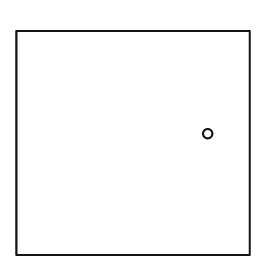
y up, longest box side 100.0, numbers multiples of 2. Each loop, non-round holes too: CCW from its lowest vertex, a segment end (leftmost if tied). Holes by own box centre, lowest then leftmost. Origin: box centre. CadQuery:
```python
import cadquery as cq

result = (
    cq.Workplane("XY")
    .moveTo(-50.0, -48.0)
    .lineTo(50.0, -48.0)
    .lineTo(50.0, 48.0)
    .lineTo(-50.0, 48.0)
    .close()
    .moveTo(32.0, 4.0)
    .circle(2.0)
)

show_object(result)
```